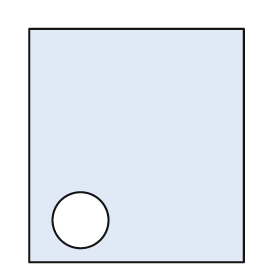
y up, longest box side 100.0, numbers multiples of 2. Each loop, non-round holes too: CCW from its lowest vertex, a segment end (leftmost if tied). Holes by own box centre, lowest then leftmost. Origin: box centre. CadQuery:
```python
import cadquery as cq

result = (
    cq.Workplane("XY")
    .moveTo(-46.0, -50.0)
    .lineTo(46.0, -50.0)
    .lineTo(46.0, 50.0)
    .lineTo(-46.0, 50.0)
    .close()
    .moveTo(-24.0, -32.0)
    .circle(12.0)
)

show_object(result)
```